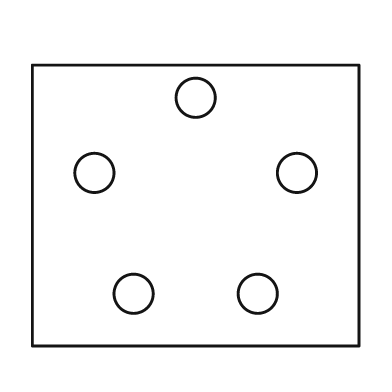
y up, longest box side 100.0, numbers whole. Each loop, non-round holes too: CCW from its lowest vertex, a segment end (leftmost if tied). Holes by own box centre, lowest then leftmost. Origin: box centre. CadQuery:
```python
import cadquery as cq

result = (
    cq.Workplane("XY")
    .moveTo(-50.0, -43.0)
    .lineTo(50.0, -43.0)
    .lineTo(50.0, 43.0)
    .lineTo(-50.0, 43.0)
    .close()
    .moveTo(-19.0, -27.0)
    .circle(6.0)
    .moveTo(19.0, -27.0)
    .circle(6.0)
    .moveTo(-31.0, 10.0)
    .circle(6.0)
    .moveTo(31.0, 10.0)
    .circle(6.0)
    .moveTo(0.0, 33.0)
    .circle(6.0)
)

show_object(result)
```